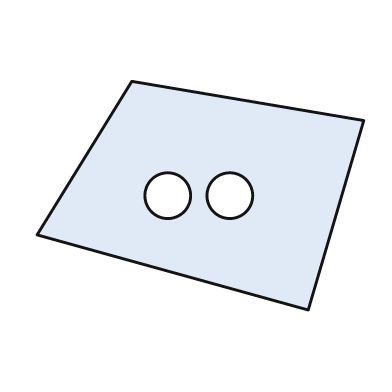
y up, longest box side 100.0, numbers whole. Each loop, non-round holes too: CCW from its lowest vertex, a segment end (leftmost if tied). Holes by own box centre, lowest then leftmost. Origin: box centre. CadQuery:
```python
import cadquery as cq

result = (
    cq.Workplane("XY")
    .moveTo(33.0, -35.0)
    .lineTo(50.0, 23.0)
    .lineTo(-21.0, 35.0)
    .lineTo(-50.0, -12.0)
    .close()
    .moveTo(-10.0, 0.0)
    .circle(7.0)
    .moveTo(9.0, 0.0)
    .circle(7.0)
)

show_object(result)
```